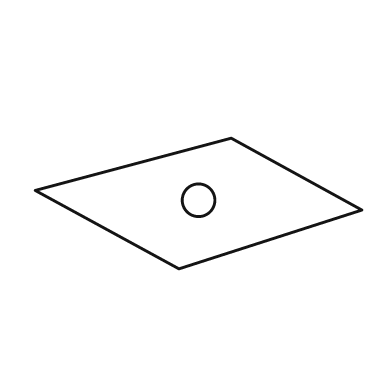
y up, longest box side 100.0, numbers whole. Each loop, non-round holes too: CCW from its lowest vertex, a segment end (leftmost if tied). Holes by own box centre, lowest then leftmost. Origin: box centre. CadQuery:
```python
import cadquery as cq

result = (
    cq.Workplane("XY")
    .moveTo(-6.0, -20.0)
    .lineTo(50.0, -2.0)
    .lineTo(10.0, 20.0)
    .lineTo(-50.0, 4.0)
    .close()
    .moveTo(0.0, 1.0)
    .circle(5.0)
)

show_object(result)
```